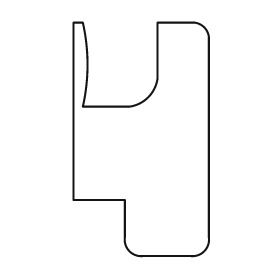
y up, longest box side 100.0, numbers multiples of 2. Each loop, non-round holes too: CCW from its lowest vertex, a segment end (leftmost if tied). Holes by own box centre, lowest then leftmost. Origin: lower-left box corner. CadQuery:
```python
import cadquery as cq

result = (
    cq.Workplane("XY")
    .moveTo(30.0, 0.0)
    .lineTo(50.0, 0.0)
    .threePointArc((56.0, 2.0), (58.0, 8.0))
    .lineTo(58.0, 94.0)
    .threePointArc((56.0, 98.0), (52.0, 100.0))
    .lineTo(36.0, 100.0)
    .lineTo(36.0, 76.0)
    .threePointArc((32.0, 68.0), (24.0, 64.0))
    .lineTo(4.0, 64.0)
    .threePointArc((6.0, 82.0), (4.0, 100.0))
    .lineTo(0.0, 100.0)
    .lineTo(0.0, 24.0)
    .lineTo(22.0, 24.0)
    .lineTo(22.0, 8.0)
    .threePointArc((24.0, 2.0), (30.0, 0.0))
    .close()
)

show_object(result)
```